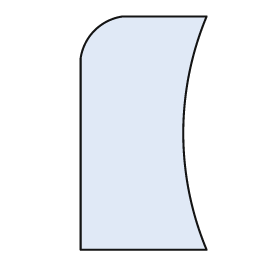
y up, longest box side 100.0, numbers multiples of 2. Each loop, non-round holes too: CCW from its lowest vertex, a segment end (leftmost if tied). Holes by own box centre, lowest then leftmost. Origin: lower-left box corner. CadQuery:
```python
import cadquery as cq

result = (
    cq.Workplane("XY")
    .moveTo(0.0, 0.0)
    .lineTo(54.0, 0.0)
    .threePointArc((44.0, 50.0), (54.0, 100.0))
    .lineTo(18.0, 100.0)
    .threePointArc((6.0, 94.0), (0.0, 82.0))
    .close()
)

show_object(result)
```